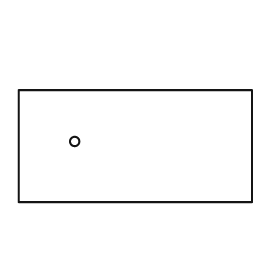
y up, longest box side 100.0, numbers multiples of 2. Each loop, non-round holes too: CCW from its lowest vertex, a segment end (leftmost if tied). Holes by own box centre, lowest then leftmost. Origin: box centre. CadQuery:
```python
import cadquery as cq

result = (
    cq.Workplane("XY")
    .moveTo(-50.0, -24.0)
    .lineTo(50.0, -24.0)
    .lineTo(50.0, 24.0)
    .lineTo(-50.0, 24.0)
    .close()
    .moveTo(-26.0, 2.0)
    .circle(2.0)
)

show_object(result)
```